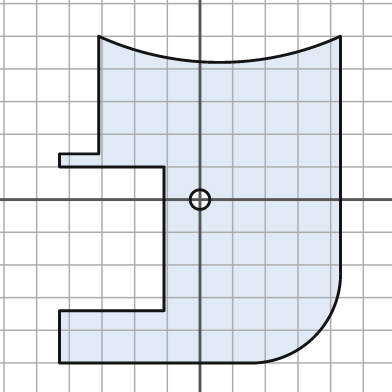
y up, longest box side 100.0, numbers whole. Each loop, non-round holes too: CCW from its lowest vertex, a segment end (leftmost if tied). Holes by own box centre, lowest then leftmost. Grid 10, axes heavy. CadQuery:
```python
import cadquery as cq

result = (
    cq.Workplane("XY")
    .moveTo(-43.0, -50.0)
    .lineTo(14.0, -50.0)
    .threePointArc((35.0, -42.0), (43.0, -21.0))
    .lineTo(43.0, 50.0)
    .threePointArc((6.0, 42.0), (-31.0, 50.0))
    .lineTo(-31.0, 14.0)
    .lineTo(-43.0, 14.0)
    .lineTo(-43.0, 10.0)
    .lineTo(-11.0, 10.0)
    .lineTo(-11.0, -34.0)
    .lineTo(-43.0, -34.0)
    .close()
    .moveTo(0.0, 0.0)
    .circle(3.0)
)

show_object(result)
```